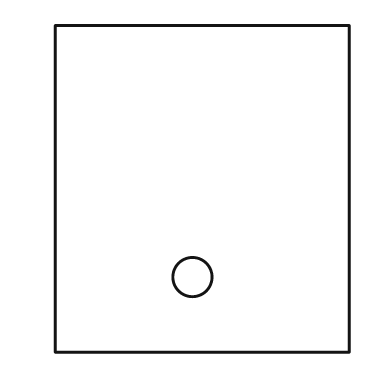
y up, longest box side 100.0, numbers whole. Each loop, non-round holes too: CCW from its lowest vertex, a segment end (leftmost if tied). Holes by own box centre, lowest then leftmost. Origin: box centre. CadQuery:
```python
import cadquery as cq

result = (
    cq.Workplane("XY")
    .moveTo(-45.0, -50.0)
    .lineTo(45.0, -50.0)
    .lineTo(45.0, 50.0)
    .lineTo(-45.0, 50.0)
    .close()
    .moveTo(-3.0, -27.0)
    .circle(6.0)
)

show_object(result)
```